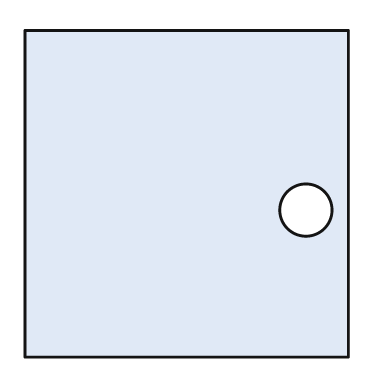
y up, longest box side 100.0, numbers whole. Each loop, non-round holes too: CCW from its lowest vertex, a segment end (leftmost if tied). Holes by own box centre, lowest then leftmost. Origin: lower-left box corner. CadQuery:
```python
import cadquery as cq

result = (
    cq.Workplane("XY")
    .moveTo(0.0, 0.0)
    .lineTo(99.0, 0.0)
    .lineTo(99.0, 100.0)
    .lineTo(0.0, 100.0)
    .close()
    .moveTo(86.0, 45.0)
    .circle(8.0)
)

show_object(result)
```